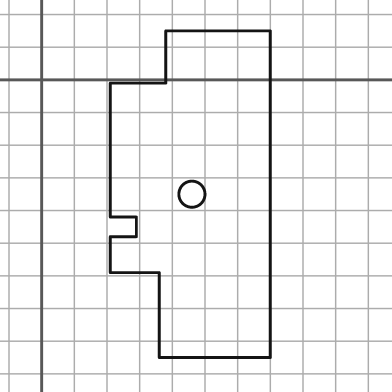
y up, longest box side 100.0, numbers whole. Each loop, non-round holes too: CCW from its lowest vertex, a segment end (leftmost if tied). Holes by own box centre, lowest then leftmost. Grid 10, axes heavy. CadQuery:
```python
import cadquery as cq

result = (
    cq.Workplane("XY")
    .moveTo(36.0, -85.0)
    .lineTo(70.0, -85.0)
    .lineTo(70.0, 15.0)
    .lineTo(38.0, 15.0)
    .lineTo(38.0, -1.0)
    .lineTo(21.0, -1.0)
    .lineTo(21.0, -42.0)
    .lineTo(29.0, -42.0)
    .lineTo(29.0, -48.0)
    .lineTo(21.0, -48.0)
    .lineTo(21.0, -59.0)
    .lineTo(36.0, -59.0)
    .close()
    .moveTo(46.0, -35.0)
    .circle(4.0)
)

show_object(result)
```